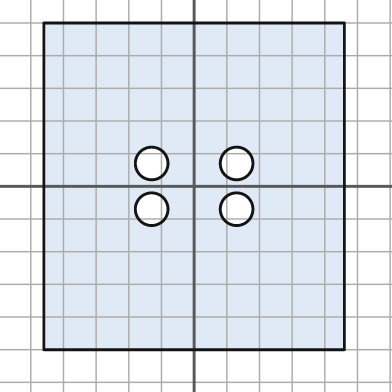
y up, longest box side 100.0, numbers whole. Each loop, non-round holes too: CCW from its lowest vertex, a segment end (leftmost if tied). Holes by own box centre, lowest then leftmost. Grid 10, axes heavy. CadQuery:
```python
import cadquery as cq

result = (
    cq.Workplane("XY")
    .moveTo(-46.0, -50.0)
    .lineTo(46.0, -50.0)
    .lineTo(46.0, 50.0)
    .lineTo(-46.0, 50.0)
    .close()
    .moveTo(-13.0, -7.0)
    .circle(5.0)
    .moveTo(13.0, -7.0)
    .circle(5.0)
    .moveTo(-13.0, 7.0)
    .circle(5.0)
    .moveTo(13.0, 7.0)
    .circle(5.0)
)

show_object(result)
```